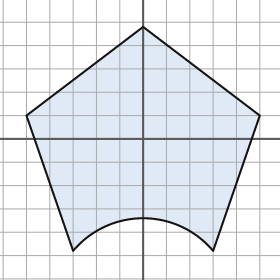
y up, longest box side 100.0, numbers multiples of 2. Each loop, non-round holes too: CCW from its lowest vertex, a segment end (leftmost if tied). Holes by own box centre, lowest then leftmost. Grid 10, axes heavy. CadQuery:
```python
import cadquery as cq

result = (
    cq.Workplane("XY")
    .moveTo(-30.0, -48.0)
    .threePointArc((0.0, -34.0), (30.0, -48.0))
    .lineTo(50.0, 10.0)
    .lineTo(0.0, 48.0)
    .lineTo(-50.0, 10.0)
    .close()
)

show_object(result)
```